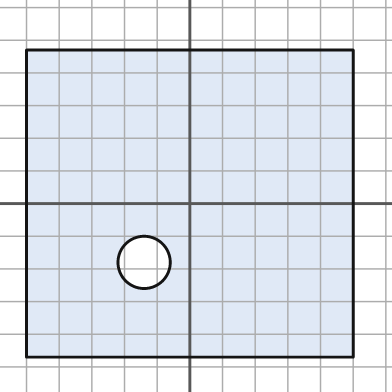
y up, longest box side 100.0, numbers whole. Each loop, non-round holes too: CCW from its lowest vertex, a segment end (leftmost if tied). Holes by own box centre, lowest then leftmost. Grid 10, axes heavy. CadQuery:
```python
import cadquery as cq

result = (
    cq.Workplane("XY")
    .moveTo(-50.0, -47.0)
    .lineTo(50.0, -47.0)
    .lineTo(50.0, 47.0)
    .lineTo(-50.0, 47.0)
    .close()
    .moveTo(-14.0, -18.0)
    .circle(8.0)
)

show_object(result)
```